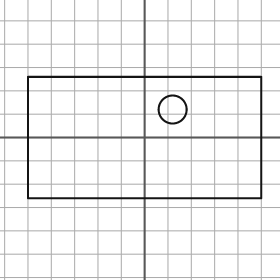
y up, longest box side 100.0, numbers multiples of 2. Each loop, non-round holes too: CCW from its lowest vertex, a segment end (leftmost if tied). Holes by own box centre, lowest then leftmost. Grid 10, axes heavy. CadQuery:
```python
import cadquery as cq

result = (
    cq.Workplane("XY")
    .moveTo(-50.0, -26.0)
    .lineTo(50.0, -26.0)
    .lineTo(50.0, 26.0)
    .lineTo(-50.0, 26.0)
    .close()
    .moveTo(12.0, 12.0)
    .circle(6.0)
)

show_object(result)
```